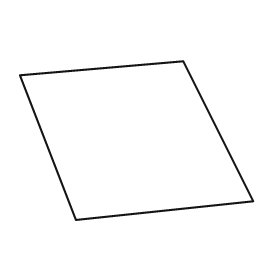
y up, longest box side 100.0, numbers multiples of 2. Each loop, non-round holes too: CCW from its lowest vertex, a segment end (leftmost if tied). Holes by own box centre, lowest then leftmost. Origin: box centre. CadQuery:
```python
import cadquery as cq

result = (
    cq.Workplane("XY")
    .moveTo(-26.0, -34.0)
    .lineTo(50.0, -26.0)
    .lineTo(20.0, 34.0)
    .lineTo(-50.0, 28.0)
    .close()
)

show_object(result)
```